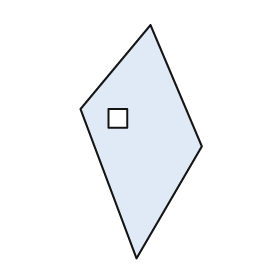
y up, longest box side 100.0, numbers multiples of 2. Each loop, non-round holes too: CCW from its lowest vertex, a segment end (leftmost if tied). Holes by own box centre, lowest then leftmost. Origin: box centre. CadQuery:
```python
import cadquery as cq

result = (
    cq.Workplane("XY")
    .moveTo(-2.0, -50.0)
    .lineTo(26.0, -2.0)
    .lineTo(4.0, 50.0)
    .lineTo(-26.0, 14.0)
    .close()
    .moveTo(-14.0, 6.0)
    .lineTo(-6.0, 6.0)
    .lineTo(-6.0, 14.0)
    .lineTo(-14.0, 14.0)
    .close()
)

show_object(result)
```